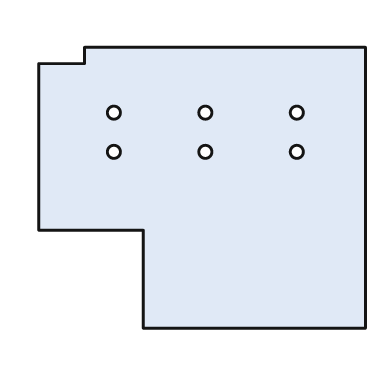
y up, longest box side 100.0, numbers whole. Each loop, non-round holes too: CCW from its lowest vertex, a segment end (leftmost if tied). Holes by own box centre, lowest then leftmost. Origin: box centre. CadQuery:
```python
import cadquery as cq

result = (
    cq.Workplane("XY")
    .moveTo(-18.0, -43.0)
    .lineTo(50.0, -43.0)
    .lineTo(50.0, 43.0)
    .lineTo(-36.0, 43.0)
    .lineTo(-36.0, 38.0)
    .lineTo(-50.0, 38.0)
    .lineTo(-50.0, -13.0)
    .lineTo(-18.0, -13.0)
    .close()
    .moveTo(-27.0, 11.0)
    .circle(2.0)
    .moveTo(1.0, 11.0)
    .circle(2.0)
    .moveTo(29.0, 11.0)
    .circle(2.0)
    .moveTo(-27.0, 23.0)
    .circle(2.0)
    .moveTo(1.0, 23.0)
    .circle(2.0)
    .moveTo(29.0, 23.0)
    .circle(2.0)
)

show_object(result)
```